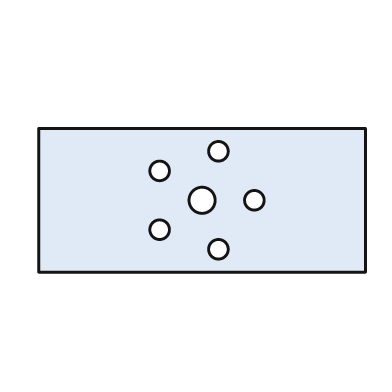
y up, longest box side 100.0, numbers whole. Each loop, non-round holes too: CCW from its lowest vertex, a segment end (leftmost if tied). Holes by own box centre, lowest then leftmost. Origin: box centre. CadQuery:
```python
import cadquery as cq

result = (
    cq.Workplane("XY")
    .moveTo(-50.0, -22.0)
    .lineTo(50.0, -22.0)
    .lineTo(50.0, 22.0)
    .lineTo(-50.0, 22.0)
    .close()
    .moveTo(5.0, -15.0)
    .circle(3.0)
    .moveTo(-13.0, -9.0)
    .circle(3.0)
    .moveTo(0.0, 0.0)
    .circle(4.0)
    .moveTo(16.0, 0.0)
    .circle(3.0)
    .moveTo(-13.0, 9.0)
    .circle(3.0)
    .moveTo(5.0, 15.0)
    .circle(3.0)
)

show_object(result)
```